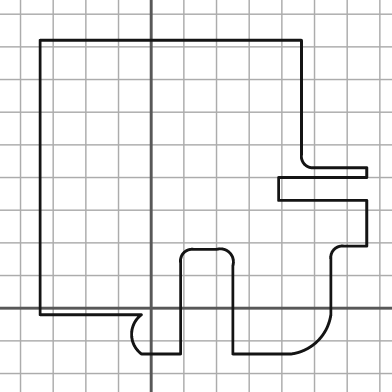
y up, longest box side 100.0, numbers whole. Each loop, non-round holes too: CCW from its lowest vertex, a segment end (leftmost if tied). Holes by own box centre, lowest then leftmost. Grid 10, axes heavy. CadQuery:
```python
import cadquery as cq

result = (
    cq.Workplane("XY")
    .moveTo(-3.0, -14.0)
    .lineTo(9.0, -14.0)
    .lineTo(9.0, 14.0)
    .threePointArc((10.0, 17.0), (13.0, 18.0))
    .lineTo(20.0, 18.0)
    .threePointArc((24.0, 17.0), (25.0, 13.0))
    .lineTo(25.0, -14.0)
    .lineTo(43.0, -14.0)
    .threePointArc((51.0, -10.0), (55.0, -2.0))
    .lineTo(55.0, 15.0)
    .threePointArc((56.0, 18.0), (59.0, 19.0))
    .lineTo(66.0, 19.0)
    .lineTo(66.0, 33.0)
    .lineTo(39.0, 33.0)
    .lineTo(39.0, 40.0)
    .lineTo(66.0, 40.0)
    .lineTo(66.0, 43.0)
    .lineTo(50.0, 43.0)
    .threePointArc((47.0, 44.0), (46.0, 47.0))
    .lineTo(46.0, 82.0)
    .lineTo(-34.0, 82.0)
    .lineTo(-34.0, -2.0)
    .lineTo(-3.0, -2.0)
    .threePointArc((-6.0, -8.0), (-3.0, -14.0))
    .close()
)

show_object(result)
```